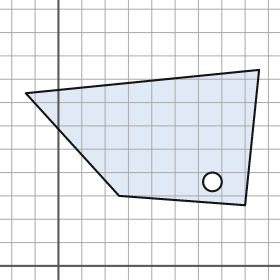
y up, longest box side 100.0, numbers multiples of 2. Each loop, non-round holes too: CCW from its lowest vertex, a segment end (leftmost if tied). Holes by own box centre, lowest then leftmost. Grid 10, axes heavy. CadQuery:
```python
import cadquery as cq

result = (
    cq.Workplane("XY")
    .moveTo(80.0, 26.0)
    .lineTo(86.0, 84.0)
    .lineTo(-14.0, 74.0)
    .lineTo(26.0, 30.0)
    .close()
    .moveTo(66.0, 36.0)
    .circle(4.0)
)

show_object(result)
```